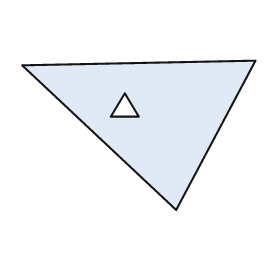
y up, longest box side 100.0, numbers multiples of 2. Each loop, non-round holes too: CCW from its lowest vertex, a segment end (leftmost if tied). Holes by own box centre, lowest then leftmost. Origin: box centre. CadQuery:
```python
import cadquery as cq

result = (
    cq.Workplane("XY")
    .moveTo(16.0, -32.0)
    .lineTo(50.0, 32.0)
    .lineTo(-50.0, 30.0)
    .close()
    .moveTo(-12.0, 8.0)
    .lineTo(0.0, 8.0)
    .lineTo(-6.0, 18.0)
    .close()
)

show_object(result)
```